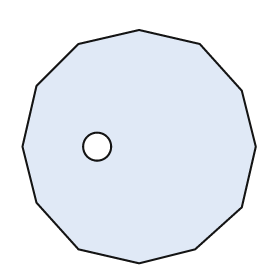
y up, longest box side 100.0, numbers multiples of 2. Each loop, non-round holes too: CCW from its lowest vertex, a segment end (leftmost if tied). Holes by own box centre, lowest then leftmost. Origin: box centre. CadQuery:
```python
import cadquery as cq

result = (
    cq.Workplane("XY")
    .moveTo(0.0, -50.0)
    .lineTo(24.0, -44.0)
    .lineTo(44.0, -26.0)
    .lineTo(50.0, 0.0)
    .lineTo(44.0, 24.0)
    .lineTo(26.0, 44.0)
    .lineTo(0.0, 50.0)
    .lineTo(-26.0, 44.0)
    .lineTo(-44.0, 26.0)
    .lineTo(-50.0, 0.0)
    .lineTo(-44.0, -24.0)
    .lineTo(-26.0, -44.0)
    .close()
    .moveTo(-18.0, 0.0)
    .circle(6.0)
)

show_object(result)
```